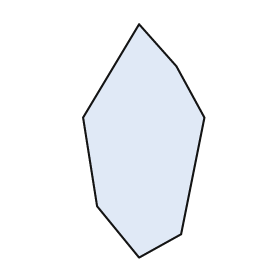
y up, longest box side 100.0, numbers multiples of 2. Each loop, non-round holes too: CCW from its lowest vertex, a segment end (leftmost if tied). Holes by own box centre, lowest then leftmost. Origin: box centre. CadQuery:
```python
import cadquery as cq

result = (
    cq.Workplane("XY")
    .moveTo(-2.0, -50.0)
    .lineTo(16.0, -40.0)
    .lineTo(26.0, 10.0)
    .lineTo(14.0, 32.0)
    .lineTo(-2.0, 50.0)
    .lineTo(-26.0, 10.0)
    .lineTo(-20.0, -28.0)
    .close()
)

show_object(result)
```